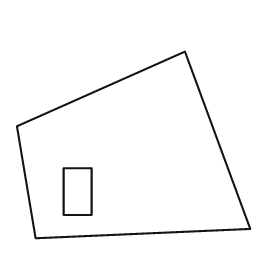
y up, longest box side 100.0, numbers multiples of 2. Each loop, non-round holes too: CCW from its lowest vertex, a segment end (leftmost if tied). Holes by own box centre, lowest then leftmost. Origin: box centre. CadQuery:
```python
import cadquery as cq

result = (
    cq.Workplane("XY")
    .moveTo(-42.0, -40.0)
    .lineTo(50.0, -36.0)
    .lineTo(22.0, 40.0)
    .lineTo(-50.0, 8.0)
    .close()
    .moveTo(-30.0, -30.0)
    .lineTo(-18.0, -30.0)
    .lineTo(-18.0, -10.0)
    .lineTo(-30.0, -10.0)
    .close()
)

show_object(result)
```